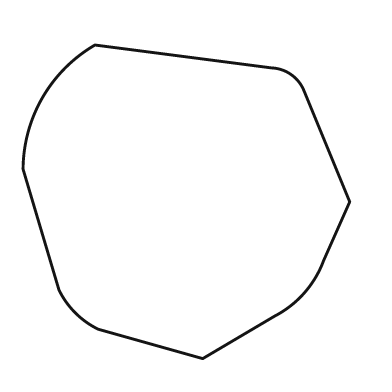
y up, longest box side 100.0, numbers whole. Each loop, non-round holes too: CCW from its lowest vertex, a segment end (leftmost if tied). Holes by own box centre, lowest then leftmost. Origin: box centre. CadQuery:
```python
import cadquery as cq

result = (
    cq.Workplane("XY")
    .moveTo(5.0, -48.0)
    .lineTo(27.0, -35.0)
    .threePointArc((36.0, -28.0), (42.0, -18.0))
    .lineTo(50.0, 0.0)
    .lineTo(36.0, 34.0)
    .threePointArc((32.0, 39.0), (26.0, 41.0))
    .lineTo(-28.0, 48.0)
    .threePointArc((-44.0, 32.0), (-50.0, 10.0))
    .lineTo(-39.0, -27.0)
    .threePointArc((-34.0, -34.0), (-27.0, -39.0))
    .close()
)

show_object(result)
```